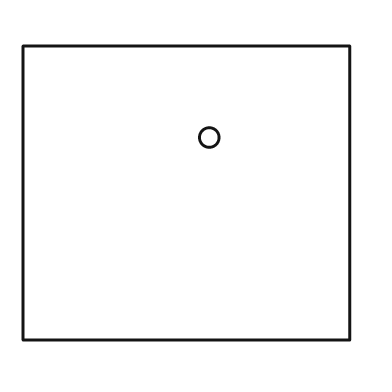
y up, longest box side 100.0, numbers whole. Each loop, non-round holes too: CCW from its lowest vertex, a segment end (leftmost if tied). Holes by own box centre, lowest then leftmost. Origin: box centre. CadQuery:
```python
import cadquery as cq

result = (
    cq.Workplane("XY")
    .moveTo(-50.0, -45.0)
    .lineTo(50.0, -45.0)
    .lineTo(50.0, 45.0)
    .lineTo(-50.0, 45.0)
    .close()
    .moveTo(7.0, 17.0)
    .circle(3.0)
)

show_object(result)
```